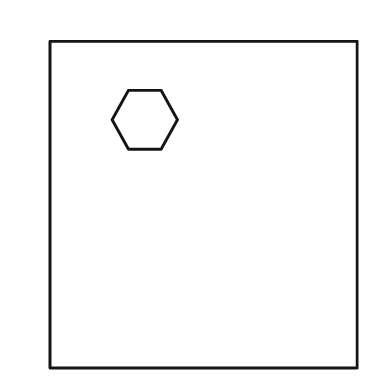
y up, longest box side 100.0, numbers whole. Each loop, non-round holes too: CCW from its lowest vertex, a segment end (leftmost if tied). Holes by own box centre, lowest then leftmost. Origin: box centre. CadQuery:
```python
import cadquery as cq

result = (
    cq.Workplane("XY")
    .moveTo(-47.0, -50.0)
    .lineTo(47.0, -50.0)
    .lineTo(47.0, 50.0)
    .lineTo(-47.0, 50.0)
    .close()
    .moveTo(-23.0, 17.0)
    .lineTo(-13.0, 17.0)
    .lineTo(-8.0, 26.0)
    .lineTo(-13.0, 35.0)
    .lineTo(-23.0, 35.0)
    .lineTo(-28.0, 26.0)
    .close()
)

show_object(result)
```